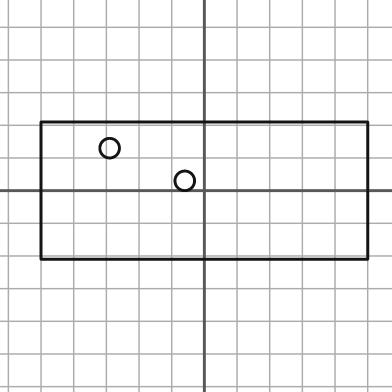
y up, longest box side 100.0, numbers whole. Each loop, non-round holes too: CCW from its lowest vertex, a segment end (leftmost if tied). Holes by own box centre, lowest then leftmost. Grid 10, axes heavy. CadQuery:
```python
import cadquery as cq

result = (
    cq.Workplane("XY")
    .moveTo(-50.0, -21.0)
    .lineTo(50.0, -21.0)
    .lineTo(50.0, 21.0)
    .lineTo(-50.0, 21.0)
    .close()
    .moveTo(-6.0, 3.0)
    .circle(3.0)
    .moveTo(-29.0, 13.0)
    .circle(3.0)
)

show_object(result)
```